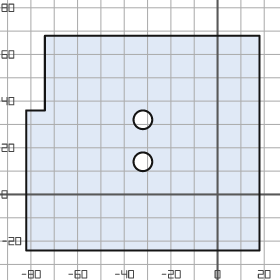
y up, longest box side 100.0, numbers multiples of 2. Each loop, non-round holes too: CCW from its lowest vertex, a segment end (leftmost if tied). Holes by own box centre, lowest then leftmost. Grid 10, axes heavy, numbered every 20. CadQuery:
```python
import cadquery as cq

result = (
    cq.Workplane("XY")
    .moveTo(-82.0, -24.0)
    .lineTo(18.0, -24.0)
    .lineTo(18.0, 68.0)
    .lineTo(-74.0, 68.0)
    .lineTo(-74.0, 36.0)
    .lineTo(-82.0, 36.0)
    .close()
    .moveTo(-32.0, 14.0)
    .circle(4.0)
    .moveTo(-32.0, 32.0)
    .circle(4.0)
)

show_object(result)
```